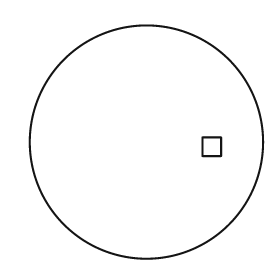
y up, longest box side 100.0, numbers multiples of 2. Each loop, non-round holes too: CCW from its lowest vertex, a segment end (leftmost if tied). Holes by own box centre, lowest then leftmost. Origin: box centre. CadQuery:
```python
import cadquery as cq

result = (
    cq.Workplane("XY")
    .moveTo(0.0, 0.0)
    .circle(50.0)
    .moveTo(24.0, -6.0)
    .lineTo(32.0, -6.0)
    .lineTo(32.0, 2.0)
    .lineTo(24.0, 2.0)
    .close()
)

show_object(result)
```